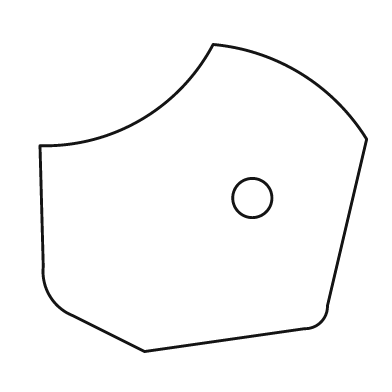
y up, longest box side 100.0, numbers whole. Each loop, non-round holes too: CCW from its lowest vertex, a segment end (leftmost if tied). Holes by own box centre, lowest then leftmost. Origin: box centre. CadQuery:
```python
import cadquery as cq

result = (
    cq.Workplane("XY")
    .moveTo(-18.0, -47.0)
    .lineTo(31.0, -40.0)
    .threePointArc((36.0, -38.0), (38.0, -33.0))
    .lineTo(50.0, 18.0)
    .threePointArc((30.0, 38.0), (3.0, 47.0))
    .threePointArc((-19.0, 24.0), (-50.0, 16.0))
    .lineTo(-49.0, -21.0)
    .threePointArc((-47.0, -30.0), (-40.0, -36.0))
    .close()
    .moveTo(15.0, 0.0)
    .circle(6.0)
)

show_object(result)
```